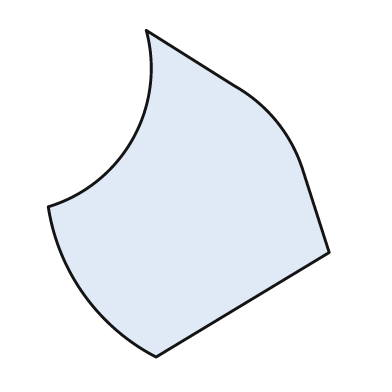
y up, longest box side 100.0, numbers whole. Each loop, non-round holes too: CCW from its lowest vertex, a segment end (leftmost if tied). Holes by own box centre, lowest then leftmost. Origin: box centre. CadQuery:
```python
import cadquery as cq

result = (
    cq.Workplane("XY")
    .moveTo(-10.0, -50.0)
    .lineTo(43.0, -18.0)
    .lineTo(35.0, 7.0)
    .threePointArc((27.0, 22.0), (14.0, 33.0))
    .lineTo(-13.0, 50.0)
    .threePointArc((-17.0, 17.0), (-43.0, -4.0))
    .threePointArc((-32.0, -31.0), (-10.0, -50.0))
    .close()
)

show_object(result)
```